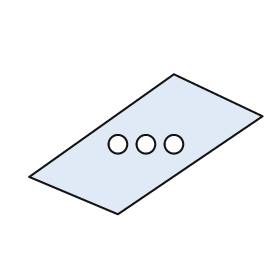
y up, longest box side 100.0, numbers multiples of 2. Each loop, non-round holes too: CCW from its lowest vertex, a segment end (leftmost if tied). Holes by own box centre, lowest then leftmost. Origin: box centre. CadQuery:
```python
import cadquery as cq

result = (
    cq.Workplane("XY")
    .moveTo(-12.0, -30.0)
    .lineTo(50.0, 12.0)
    .lineTo(12.0, 30.0)
    .lineTo(-50.0, -14.0)
    .close()
    .moveTo(-12.0, 0.0)
    .circle(4.0)
    .moveTo(0.0, 0.0)
    .circle(4.0)
    .moveTo(12.0, 0.0)
    .circle(4.0)
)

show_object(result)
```